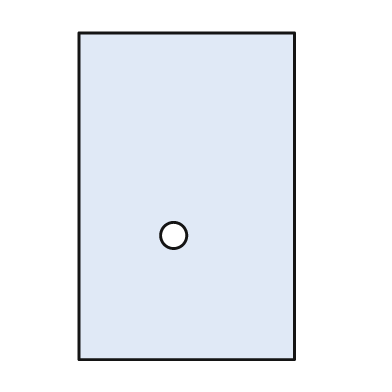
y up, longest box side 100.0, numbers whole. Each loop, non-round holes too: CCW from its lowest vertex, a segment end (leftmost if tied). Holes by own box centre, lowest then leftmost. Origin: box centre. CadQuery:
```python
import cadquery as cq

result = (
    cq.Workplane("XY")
    .moveTo(-33.0, -50.0)
    .lineTo(33.0, -50.0)
    .lineTo(33.0, 50.0)
    .lineTo(-33.0, 50.0)
    .close()
    .moveTo(-4.0, -12.0)
    .circle(4.0)
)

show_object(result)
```